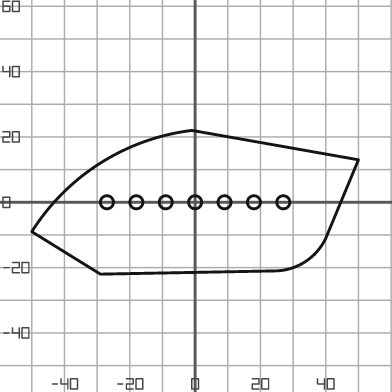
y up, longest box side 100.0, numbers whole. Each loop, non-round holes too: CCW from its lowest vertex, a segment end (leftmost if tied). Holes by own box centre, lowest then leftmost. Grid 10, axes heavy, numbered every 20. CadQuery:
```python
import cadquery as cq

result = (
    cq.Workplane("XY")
    .moveTo(-29.0, -22.0)
    .lineTo(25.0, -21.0)
    .threePointArc((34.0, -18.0), (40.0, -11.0))
    .lineTo(50.0, 13.0)
    .lineTo(-1.0, 22.0)
    .threePointArc((-29.0, 12.0), (-50.0, -9.0))
    .close()
    .moveTo(-27.0, 0.0)
    .circle(2.0)
    .moveTo(-18.0, 0.0)
    .circle(2.0)
    .moveTo(-9.0, 0.0)
    .circle(2.0)
    .moveTo(0.0, 0.0)
    .circle(2.0)
    .moveTo(9.0, 0.0)
    .circle(2.0)
    .moveTo(18.0, 0.0)
    .circle(2.0)
    .moveTo(27.0, 0.0)
    .circle(2.0)
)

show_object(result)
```